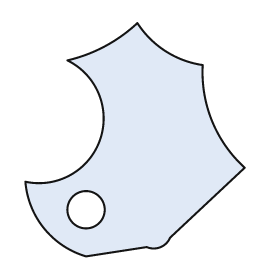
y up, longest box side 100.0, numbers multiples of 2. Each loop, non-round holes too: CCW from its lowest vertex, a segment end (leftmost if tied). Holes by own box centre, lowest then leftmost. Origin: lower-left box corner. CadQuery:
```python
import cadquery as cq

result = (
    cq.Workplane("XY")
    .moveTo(26.0, 0.0)
    .lineTo(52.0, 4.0)
    .threePointArc((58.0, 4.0), (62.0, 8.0))
    .lineTo(94.0, 38.0)
    .threePointArc((80.0, 58.0), (76.0, 82.0))
    .threePointArc((60.0, 88.0), (48.0, 100.0))
    .threePointArc((34.0, 90.0), (18.0, 84.0))
    .threePointArc((32.0, 50.0), (0.0, 32.0))
    .threePointArc((8.0, 12.0), (26.0, 0.0))
    .close()
    .moveTo(26.0, 20.0)
    .circle(8.0)
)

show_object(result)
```